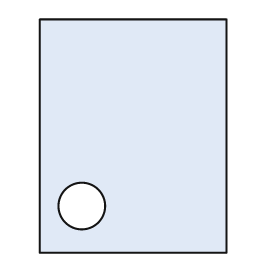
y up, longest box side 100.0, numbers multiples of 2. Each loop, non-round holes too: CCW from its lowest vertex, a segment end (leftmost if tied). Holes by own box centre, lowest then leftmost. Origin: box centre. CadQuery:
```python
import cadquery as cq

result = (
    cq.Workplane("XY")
    .moveTo(-40.0, -50.0)
    .lineTo(40.0, -50.0)
    .lineTo(40.0, 50.0)
    .lineTo(-40.0, 50.0)
    .close()
    .moveTo(-22.0, -30.0)
    .circle(10.0)
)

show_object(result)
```